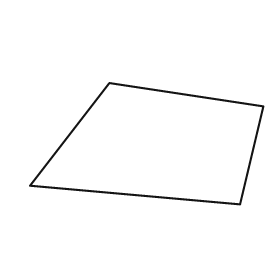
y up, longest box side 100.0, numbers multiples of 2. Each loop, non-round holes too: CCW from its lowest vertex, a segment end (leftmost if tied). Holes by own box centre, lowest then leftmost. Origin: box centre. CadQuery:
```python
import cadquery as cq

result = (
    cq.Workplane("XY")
    .moveTo(40.0, -26.0)
    .lineTo(50.0, 16.0)
    .lineTo(-16.0, 26.0)
    .lineTo(-50.0, -18.0)
    .close()
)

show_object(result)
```